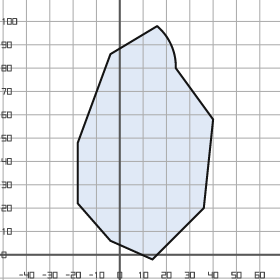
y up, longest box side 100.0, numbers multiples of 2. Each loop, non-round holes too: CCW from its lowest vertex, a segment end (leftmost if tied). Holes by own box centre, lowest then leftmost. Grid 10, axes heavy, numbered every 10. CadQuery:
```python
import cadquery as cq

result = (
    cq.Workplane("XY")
    .moveTo(14.0, -2.0)
    .lineTo(36.0, 20.0)
    .lineTo(40.0, 58.0)
    .lineTo(24.0, 80.0)
    .threePointArc((22.0, 90.0), (16.0, 98.0))
    .lineTo(-4.0, 86.0)
    .lineTo(-18.0, 48.0)
    .lineTo(-18.0, 22.0)
    .lineTo(-4.0, 6.0)
    .close()
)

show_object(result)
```